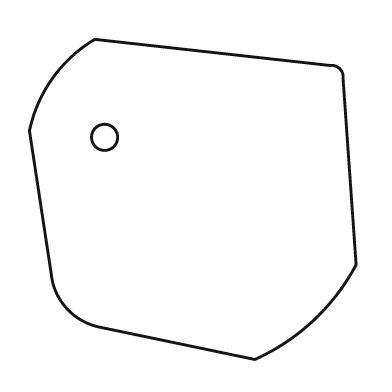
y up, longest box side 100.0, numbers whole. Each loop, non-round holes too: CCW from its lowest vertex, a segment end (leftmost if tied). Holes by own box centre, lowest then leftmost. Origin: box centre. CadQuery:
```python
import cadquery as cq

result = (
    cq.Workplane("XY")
    .moveTo(19.0, -49.0)
    .threePointArc((37.0, -37.0), (50.0, -20.0))
    .lineTo(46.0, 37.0)
    .threePointArc((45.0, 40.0), (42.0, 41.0))
    .lineTo(-30.0, 49.0)
    .threePointArc((-43.0, 37.0), (-50.0, 21.0))
    .lineTo(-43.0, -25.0)
    .threePointArc((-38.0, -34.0), (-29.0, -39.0))
    .close()
    .moveTo(-27.0, 19.0)
    .circle(4.0)
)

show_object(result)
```